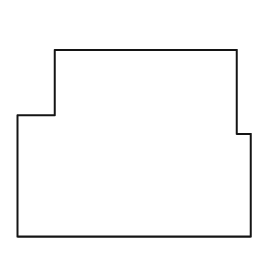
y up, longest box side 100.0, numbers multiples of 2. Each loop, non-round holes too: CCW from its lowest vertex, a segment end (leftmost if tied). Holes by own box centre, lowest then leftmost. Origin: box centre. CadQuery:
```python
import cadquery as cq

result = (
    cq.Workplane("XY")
    .moveTo(-50.0, -40.0)
    .lineTo(50.0, -40.0)
    .lineTo(50.0, 4.0)
    .lineTo(44.0, 4.0)
    .lineTo(44.0, 40.0)
    .lineTo(-34.0, 40.0)
    .lineTo(-34.0, 12.0)
    .lineTo(-50.0, 12.0)
    .close()
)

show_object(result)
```